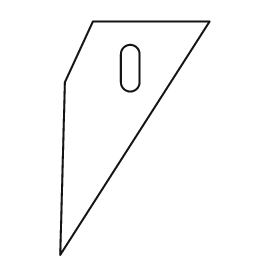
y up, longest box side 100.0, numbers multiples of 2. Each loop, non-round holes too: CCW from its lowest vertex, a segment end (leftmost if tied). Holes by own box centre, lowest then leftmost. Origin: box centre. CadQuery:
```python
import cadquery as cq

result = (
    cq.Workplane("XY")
    .moveTo(-32.0, -50.0)
    .lineTo(32.0, 50.0)
    .lineTo(-18.0, 50.0)
    .lineTo(-30.0, 24.0)
    .close()
    .moveTo(-6.0, 24.0)
    .threePointArc((-2.0, 20.0), (2.0, 24.0))
    .lineTo(2.0, 36.0)
    .threePointArc((-2.0, 40.0), (-6.0, 36.0))
    .close()
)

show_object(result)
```